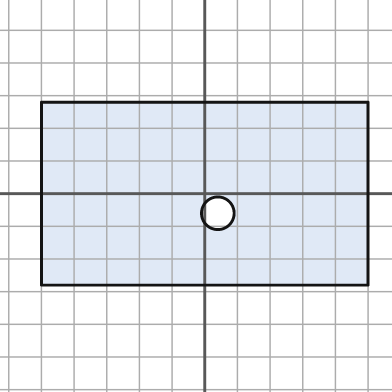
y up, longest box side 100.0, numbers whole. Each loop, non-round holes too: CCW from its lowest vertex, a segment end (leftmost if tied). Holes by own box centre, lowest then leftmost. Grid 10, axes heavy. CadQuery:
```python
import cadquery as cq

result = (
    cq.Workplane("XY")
    .moveTo(-50.0, -28.0)
    .lineTo(50.0, -28.0)
    .lineTo(50.0, 28.0)
    .lineTo(-50.0, 28.0)
    .close()
    .moveTo(4.0, -6.0)
    .circle(5.0)
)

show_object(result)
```